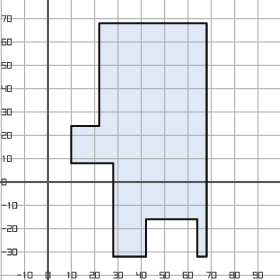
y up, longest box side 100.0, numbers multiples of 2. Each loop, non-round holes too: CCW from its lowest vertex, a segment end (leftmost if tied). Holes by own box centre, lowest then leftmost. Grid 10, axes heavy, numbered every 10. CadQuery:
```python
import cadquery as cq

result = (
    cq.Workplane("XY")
    .moveTo(28.0, -32.0)
    .lineTo(42.0, -32.0)
    .lineTo(42.0, -16.0)
    .lineTo(64.0, -16.0)
    .lineTo(64.0, -32.0)
    .lineTo(68.0, -32.0)
    .lineTo(68.0, 68.0)
    .lineTo(22.0, 68.0)
    .lineTo(22.0, 24.0)
    .lineTo(10.0, 24.0)
    .lineTo(10.0, 8.0)
    .lineTo(28.0, 8.0)
    .close()
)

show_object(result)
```